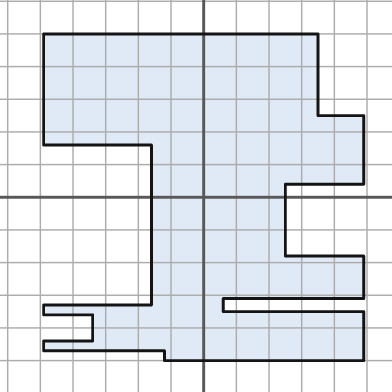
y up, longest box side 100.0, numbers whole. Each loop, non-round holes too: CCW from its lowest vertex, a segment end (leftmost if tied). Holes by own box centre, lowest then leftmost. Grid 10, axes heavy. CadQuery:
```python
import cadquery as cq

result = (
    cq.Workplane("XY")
    .moveTo(-12.0, -50.0)
    .lineTo(49.0, -50.0)
    .lineTo(49.0, -35.0)
    .lineTo(6.0, -35.0)
    .lineTo(6.0, -31.0)
    .lineTo(49.0, -31.0)
    .lineTo(49.0, -18.0)
    .lineTo(25.0, -18.0)
    .lineTo(25.0, 4.0)
    .lineTo(49.0, 4.0)
    .lineTo(49.0, 25.0)
    .lineTo(35.0, 25.0)
    .lineTo(35.0, 50.0)
    .lineTo(-49.0, 50.0)
    .lineTo(-49.0, 16.0)
    .lineTo(-16.0, 16.0)
    .lineTo(-16.0, -33.0)
    .lineTo(-49.0, -33.0)
    .lineTo(-49.0, -36.0)
    .lineTo(-34.0, -36.0)
    .lineTo(-34.0, -44.0)
    .lineTo(-49.0, -44.0)
    .lineTo(-49.0, -47.0)
    .lineTo(-12.0, -47.0)
    .close()
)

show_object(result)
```